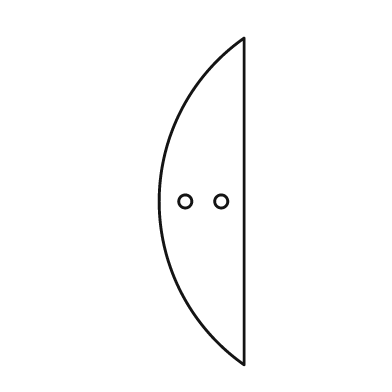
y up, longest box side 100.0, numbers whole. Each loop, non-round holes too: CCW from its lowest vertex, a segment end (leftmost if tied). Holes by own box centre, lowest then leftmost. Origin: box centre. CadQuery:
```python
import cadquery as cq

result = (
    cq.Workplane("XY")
    .moveTo(13.0, -50.0)
    .lineTo(13.0, 50.0)
    .threePointArc((-13.0, 0.0), (13.0, -50.0))
    .close()
    .moveTo(-5.0, 0.0)
    .circle(2.0)
    .moveTo(6.0, 0.0)
    .circle(2.0)
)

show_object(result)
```